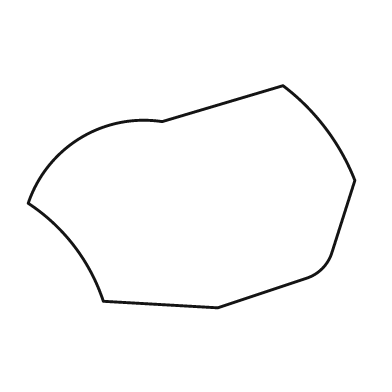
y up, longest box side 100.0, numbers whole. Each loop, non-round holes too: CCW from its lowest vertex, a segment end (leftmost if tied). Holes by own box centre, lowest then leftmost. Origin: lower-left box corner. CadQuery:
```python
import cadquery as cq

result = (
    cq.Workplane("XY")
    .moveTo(58.0, 0.0)
    .lineTo(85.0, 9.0)
    .threePointArc((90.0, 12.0), (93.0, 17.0))
    .lineTo(100.0, 39.0)
    .threePointArc((91.0, 55.0), (78.0, 68.0))
    .lineTo(41.0, 57.0)
    .threePointArc((16.0, 52.0), (0.0, 32.0))
    .threePointArc((14.0, 19.0), (23.0, 2.0))
    .close()
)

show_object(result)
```